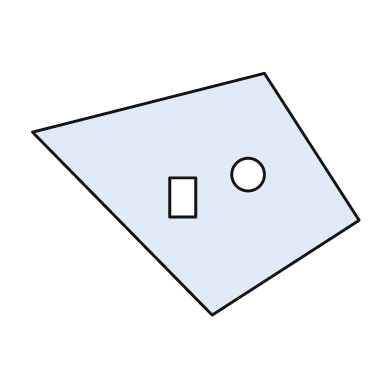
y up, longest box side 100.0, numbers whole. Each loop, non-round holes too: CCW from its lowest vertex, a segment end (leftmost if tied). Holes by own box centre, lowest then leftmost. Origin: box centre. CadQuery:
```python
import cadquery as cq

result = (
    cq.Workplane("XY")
    .moveTo(5.0, -37.0)
    .lineTo(50.0, -8.0)
    .lineTo(21.0, 37.0)
    .lineTo(-50.0, 19.0)
    .close()
    .moveTo(-8.0, -7.0)
    .lineTo(0.0, -7.0)
    .lineTo(0.0, 5.0)
    .lineTo(-8.0, 5.0)
    .close()
    .moveTo(16.0, 6.0)
    .circle(5.0)
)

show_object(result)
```